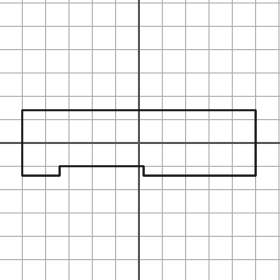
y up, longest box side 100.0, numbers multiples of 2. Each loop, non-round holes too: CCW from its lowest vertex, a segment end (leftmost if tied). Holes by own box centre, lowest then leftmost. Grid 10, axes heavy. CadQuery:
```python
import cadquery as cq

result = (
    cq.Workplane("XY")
    .moveTo(-50.0, -14.0)
    .lineTo(-34.0, -14.0)
    .lineTo(-34.0, -10.0)
    .lineTo(2.0, -10.0)
    .lineTo(2.0, -14.0)
    .lineTo(50.0, -14.0)
    .lineTo(50.0, 14.0)
    .lineTo(-50.0, 14.0)
    .close()
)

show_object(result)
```